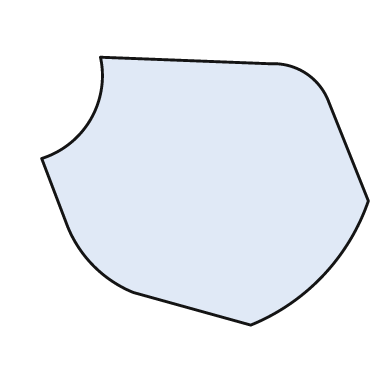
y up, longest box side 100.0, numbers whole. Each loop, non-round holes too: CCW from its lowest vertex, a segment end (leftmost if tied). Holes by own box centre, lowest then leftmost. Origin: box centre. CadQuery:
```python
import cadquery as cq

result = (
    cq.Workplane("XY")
    .moveTo(14.0, -41.0)
    .threePointArc((36.0, -26.0), (50.0, -3.0))
    .lineTo(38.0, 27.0)
    .threePointArc((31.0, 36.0), (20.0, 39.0))
    .lineTo(-32.0, 41.0)
    .threePointArc((-35.0, 22.0), (-50.0, 10.0))
    .lineTo(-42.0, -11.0)
    .threePointArc((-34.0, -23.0), (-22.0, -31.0))
    .close()
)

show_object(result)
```